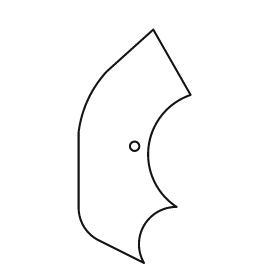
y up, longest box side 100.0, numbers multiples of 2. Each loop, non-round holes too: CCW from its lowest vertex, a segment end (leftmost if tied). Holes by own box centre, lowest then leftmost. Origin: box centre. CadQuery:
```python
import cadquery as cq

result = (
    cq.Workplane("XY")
    .moveTo(4.0, -50.0)
    .threePointArc((4.0, -34.0), (18.0, -26.0))
    .threePointArc((6.0, 0.0), (24.0, 22.0))
    .lineTo(8.0, 50.0)
    .lineTo(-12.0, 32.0)
    .threePointArc((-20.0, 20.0), (-24.0, 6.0))
    .lineTo(-24.0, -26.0)
    .threePointArc((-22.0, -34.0), (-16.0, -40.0))
    .close()
    .moveTo(0.0, 0.0)
    .circle(2.0)
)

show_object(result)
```